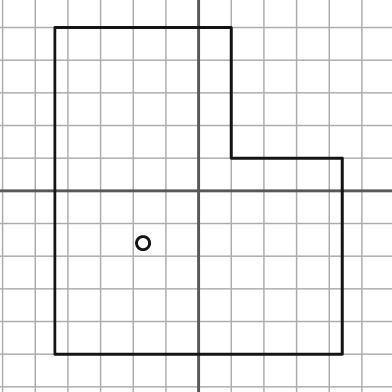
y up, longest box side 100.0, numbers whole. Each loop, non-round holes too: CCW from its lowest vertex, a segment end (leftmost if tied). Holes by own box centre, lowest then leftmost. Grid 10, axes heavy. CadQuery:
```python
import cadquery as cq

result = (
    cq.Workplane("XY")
    .moveTo(-44.0, -50.0)
    .lineTo(44.0, -50.0)
    .lineTo(44.0, 10.0)
    .lineTo(10.0, 10.0)
    .lineTo(10.0, 50.0)
    .lineTo(-44.0, 50.0)
    .close()
    .moveTo(-17.0, -16.0)
    .circle(2.0)
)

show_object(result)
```